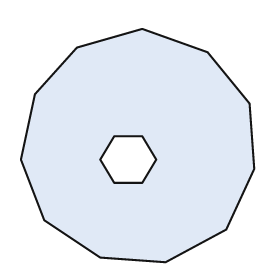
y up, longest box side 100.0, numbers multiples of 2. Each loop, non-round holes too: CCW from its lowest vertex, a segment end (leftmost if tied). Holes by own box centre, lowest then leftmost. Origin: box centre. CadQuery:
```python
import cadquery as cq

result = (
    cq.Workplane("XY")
    .moveTo(12.0, -50.0)
    .lineTo(38.0, -36.0)
    .lineTo(50.0, -10.0)
    .lineTo(48.0, 18.0)
    .lineTo(30.0, 40.0)
    .lineTo(2.0, 50.0)
    .lineTo(-26.0, 42.0)
    .lineTo(-44.0, 22.0)
    .lineTo(-50.0, -6.0)
    .lineTo(-40.0, -32.0)
    .lineTo(-16.0, -48.0)
    .close()
    .moveTo(-10.0, -16.0)
    .lineTo(2.0, -16.0)
    .lineTo(8.0, -6.0)
    .lineTo(2.0, 4.0)
    .lineTo(-10.0, 4.0)
    .lineTo(-16.0, -6.0)
    .close()
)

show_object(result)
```